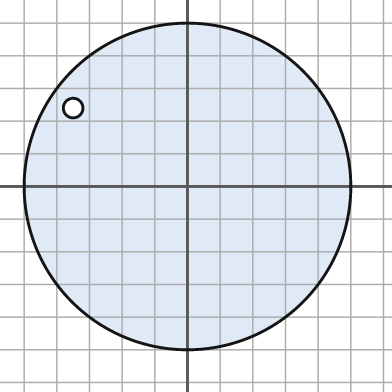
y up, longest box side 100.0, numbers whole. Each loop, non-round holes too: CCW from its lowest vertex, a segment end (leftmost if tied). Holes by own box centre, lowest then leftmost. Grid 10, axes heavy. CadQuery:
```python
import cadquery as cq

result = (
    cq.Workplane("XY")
    .moveTo(0.0, 0.0)
    .circle(50.0)
    .moveTo(-35.0, 24.0)
    .circle(3.0)
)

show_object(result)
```